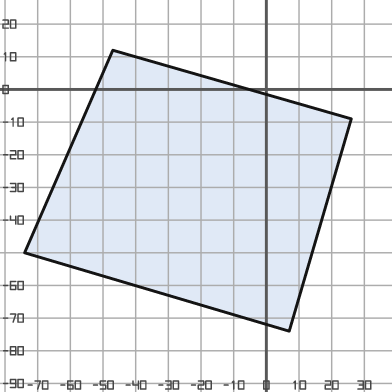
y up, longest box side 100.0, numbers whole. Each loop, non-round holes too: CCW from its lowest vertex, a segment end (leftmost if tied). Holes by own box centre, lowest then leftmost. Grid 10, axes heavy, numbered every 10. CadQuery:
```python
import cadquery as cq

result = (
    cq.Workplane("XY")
    .moveTo(7.0, -74.0)
    .lineTo(26.0, -9.0)
    .lineTo(-47.0, 12.0)
    .lineTo(-74.0, -50.0)
    .close()
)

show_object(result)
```